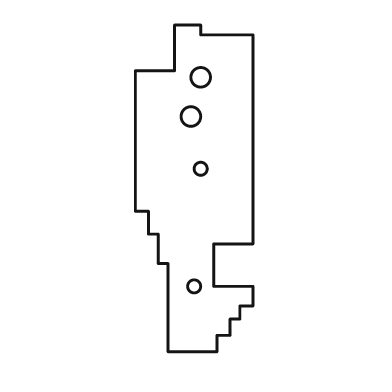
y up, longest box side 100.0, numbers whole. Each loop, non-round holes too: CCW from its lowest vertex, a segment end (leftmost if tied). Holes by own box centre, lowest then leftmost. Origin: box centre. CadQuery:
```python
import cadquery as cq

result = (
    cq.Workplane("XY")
    .moveTo(-8.0, -50.0)
    .lineTo(7.0, -50.0)
    .lineTo(7.0, -45.0)
    .lineTo(11.0, -45.0)
    .lineTo(11.0, -40.0)
    .lineTo(14.0, -40.0)
    .lineTo(14.0, -36.0)
    .lineTo(18.0, -36.0)
    .lineTo(18.0, -30.0)
    .lineTo(6.0, -30.0)
    .lineTo(6.0, -17.0)
    .lineTo(18.0, -17.0)
    .lineTo(18.0, 47.0)
    .lineTo(2.0, 47.0)
    .lineTo(2.0, 50.0)
    .lineTo(-6.0, 50.0)
    .lineTo(-6.0, 36.0)
    .lineTo(-18.0, 36.0)
    .lineTo(-18.0, -7.0)
    .lineTo(-14.0, -7.0)
    .lineTo(-14.0, -14.0)
    .lineTo(-11.0, -14.0)
    .lineTo(-11.0, -23.0)
    .lineTo(-8.0, -23.0)
    .close()
    .moveTo(0.0, -30.0)
    .circle(2.0)
    .moveTo(2.0, 6.0)
    .circle(2.0)
    .moveTo(-1.0, 22.0)
    .circle(3.0)
    .moveTo(2.0, 34.0)
    .circle(3.0)
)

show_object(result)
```